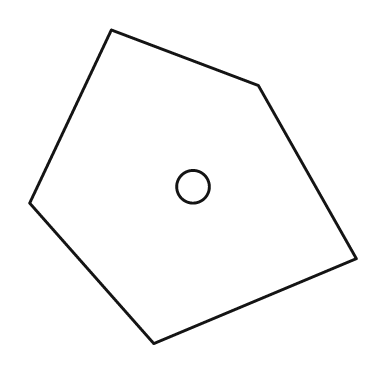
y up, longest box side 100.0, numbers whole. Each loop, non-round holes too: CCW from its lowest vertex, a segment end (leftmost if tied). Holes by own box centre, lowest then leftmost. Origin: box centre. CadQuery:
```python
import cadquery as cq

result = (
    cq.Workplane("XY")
    .moveTo(-12.0, -48.0)
    .lineTo(50.0, -22.0)
    .lineTo(20.0, 31.0)
    .lineTo(-25.0, 48.0)
    .lineTo(-50.0, -5.0)
    .close()
    .moveTo(0.0, 0.0)
    .circle(5.0)
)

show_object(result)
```